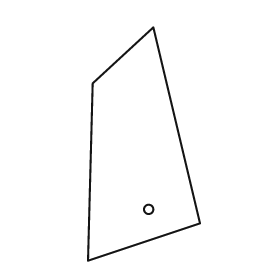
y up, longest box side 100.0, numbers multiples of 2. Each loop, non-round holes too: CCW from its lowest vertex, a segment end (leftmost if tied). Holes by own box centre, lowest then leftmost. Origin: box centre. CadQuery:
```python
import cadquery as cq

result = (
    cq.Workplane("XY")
    .moveTo(-24.0, -50.0)
    .lineTo(24.0, -34.0)
    .lineTo(4.0, 50.0)
    .lineTo(-22.0, 26.0)
    .close()
    .moveTo(2.0, -28.0)
    .circle(2.0)
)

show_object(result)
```